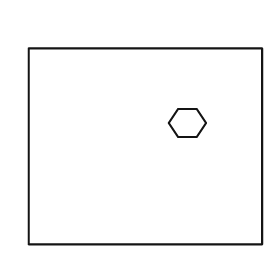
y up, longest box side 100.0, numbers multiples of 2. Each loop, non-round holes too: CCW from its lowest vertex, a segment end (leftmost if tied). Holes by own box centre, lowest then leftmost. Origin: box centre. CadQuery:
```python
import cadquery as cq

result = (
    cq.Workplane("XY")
    .moveTo(-50.0, -42.0)
    .lineTo(50.0, -42.0)
    .lineTo(50.0, 42.0)
    .lineTo(-50.0, 42.0)
    .close()
    .moveTo(14.0, 4.0)
    .lineTo(22.0, 4.0)
    .lineTo(26.0, 10.0)
    .lineTo(22.0, 16.0)
    .lineTo(14.0, 16.0)
    .lineTo(10.0, 10.0)
    .close()
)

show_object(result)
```